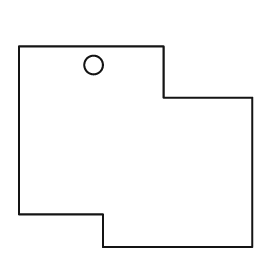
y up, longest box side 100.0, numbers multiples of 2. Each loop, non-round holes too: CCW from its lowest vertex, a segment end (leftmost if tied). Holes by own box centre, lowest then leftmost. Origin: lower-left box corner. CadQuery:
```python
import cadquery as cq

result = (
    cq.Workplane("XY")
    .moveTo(36.0, 0.0)
    .lineTo(100.0, 0.0)
    .lineTo(100.0, 64.0)
    .lineTo(62.0, 64.0)
    .lineTo(62.0, 86.0)
    .lineTo(0.0, 86.0)
    .lineTo(0.0, 14.0)
    .lineTo(36.0, 14.0)
    .close()
    .moveTo(32.0, 78.0)
    .circle(4.0)
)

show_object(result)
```